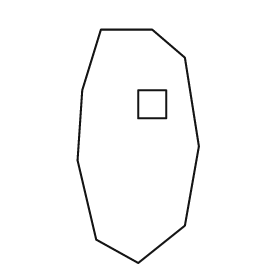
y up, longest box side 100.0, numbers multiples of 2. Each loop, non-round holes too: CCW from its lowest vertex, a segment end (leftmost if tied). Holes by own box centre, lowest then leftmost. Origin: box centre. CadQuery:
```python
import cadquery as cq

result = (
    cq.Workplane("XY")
    .moveTo(0.0, -50.0)
    .lineTo(20.0, -34.0)
    .lineTo(26.0, 0.0)
    .lineTo(20.0, 38.0)
    .lineTo(6.0, 50.0)
    .lineTo(-16.0, 50.0)
    .lineTo(-24.0, 24.0)
    .lineTo(-26.0, -6.0)
    .lineTo(-18.0, -40.0)
    .close()
    .moveTo(0.0, 12.0)
    .lineTo(12.0, 12.0)
    .lineTo(12.0, 24.0)
    .lineTo(0.0, 24.0)
    .close()
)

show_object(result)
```